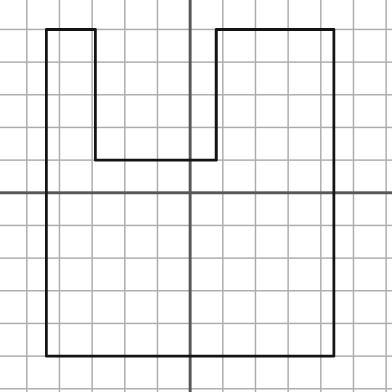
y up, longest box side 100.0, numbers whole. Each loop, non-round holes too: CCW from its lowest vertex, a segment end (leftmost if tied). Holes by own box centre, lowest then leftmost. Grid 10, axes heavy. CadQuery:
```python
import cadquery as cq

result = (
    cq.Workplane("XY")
    .moveTo(-44.0, -50.0)
    .lineTo(44.0, -50.0)
    .lineTo(44.0, 50.0)
    .lineTo(8.0, 50.0)
    .lineTo(8.0, 10.0)
    .lineTo(-29.0, 10.0)
    .lineTo(-29.0, 50.0)
    .lineTo(-44.0, 50.0)
    .close()
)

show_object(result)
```